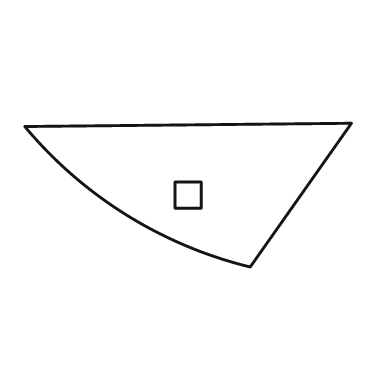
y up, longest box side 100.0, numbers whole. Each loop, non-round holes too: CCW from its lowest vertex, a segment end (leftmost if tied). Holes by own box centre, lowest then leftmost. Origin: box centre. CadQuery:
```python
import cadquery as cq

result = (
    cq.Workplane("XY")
    .moveTo(19.0, -22.0)
    .lineTo(50.0, 22.0)
    .lineTo(-50.0, 21.0)
    .threePointArc((-19.0, -6.0), (19.0, -22.0))
    .close()
    .moveTo(-4.0, -4.0)
    .lineTo(4.0, -4.0)
    .lineTo(4.0, 4.0)
    .lineTo(-4.0, 4.0)
    .close()
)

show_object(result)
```